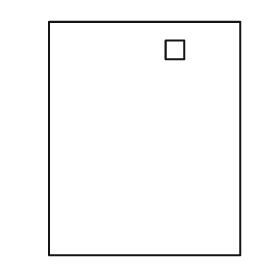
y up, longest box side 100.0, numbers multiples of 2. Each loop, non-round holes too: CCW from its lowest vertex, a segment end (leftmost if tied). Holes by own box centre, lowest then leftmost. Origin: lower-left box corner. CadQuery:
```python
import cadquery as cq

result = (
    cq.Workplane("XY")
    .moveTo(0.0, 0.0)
    .lineTo(82.0, 0.0)
    .lineTo(82.0, 100.0)
    .lineTo(0.0, 100.0)
    .close()
    .moveTo(50.0, 84.0)
    .lineTo(58.0, 84.0)
    .lineTo(58.0, 92.0)
    .lineTo(50.0, 92.0)
    .close()
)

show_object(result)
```